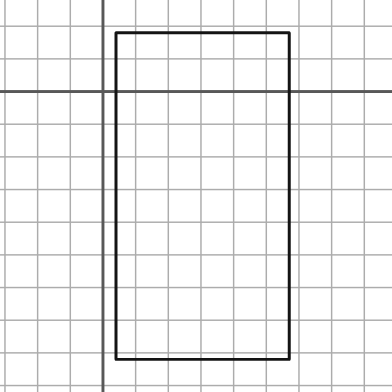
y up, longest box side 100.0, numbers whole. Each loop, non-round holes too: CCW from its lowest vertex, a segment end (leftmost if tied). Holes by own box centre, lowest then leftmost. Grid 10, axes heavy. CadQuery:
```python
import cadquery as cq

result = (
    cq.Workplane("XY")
    .moveTo(4.0, -82.0)
    .lineTo(57.0, -82.0)
    .lineTo(57.0, 18.0)
    .lineTo(4.0, 18.0)
    .close()
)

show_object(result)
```